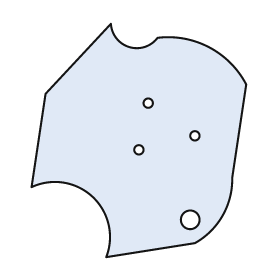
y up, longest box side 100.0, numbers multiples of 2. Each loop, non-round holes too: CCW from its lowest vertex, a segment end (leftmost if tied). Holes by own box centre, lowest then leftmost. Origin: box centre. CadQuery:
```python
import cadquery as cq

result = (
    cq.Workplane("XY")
    .moveTo(-14.0, -50.0)
    .lineTo(24.0, -44.0)
    .threePointArc((36.0, -32.0), (40.0, -16.0))
    .lineTo(46.0, 24.0)
    .threePointArc((30.0, 40.0), (8.0, 44.0))
    .threePointArc((-4.0, 40.0), (-12.0, 50.0))
    .lineTo(-40.0, 20.0)
    .lineTo(-46.0, -20.0)
    .threePointArc((-20.0, -24.0), (-14.0, -50.0))
    .close()
    .moveTo(22.0, -34.0)
    .circle(4.0)
    .moveTo(0.0, -4.0)
    .circle(2.0)
    .moveTo(24.0, 2.0)
    .circle(2.0)
    .moveTo(4.0, 16.0)
    .circle(2.0)
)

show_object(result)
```